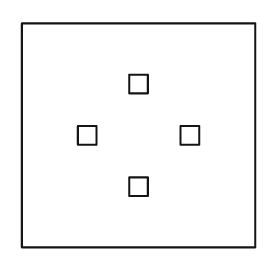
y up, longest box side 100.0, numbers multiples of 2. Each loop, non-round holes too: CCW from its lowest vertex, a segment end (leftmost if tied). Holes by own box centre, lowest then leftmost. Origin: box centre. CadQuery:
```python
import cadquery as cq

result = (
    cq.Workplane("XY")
    .moveTo(-50.0, -48.0)
    .lineTo(50.0, -48.0)
    .lineTo(50.0, 48.0)
    .lineTo(-50.0, 48.0)
    .close()
    .moveTo(-4.0, -26.0)
    .lineTo(4.0, -26.0)
    .lineTo(4.0, -18.0)
    .lineTo(-4.0, -18.0)
    .close()
    .moveTo(-26.0, -4.0)
    .lineTo(-18.0, -4.0)
    .lineTo(-18.0, 4.0)
    .lineTo(-26.0, 4.0)
    .close()
    .moveTo(18.0, -4.0)
    .lineTo(26.0, -4.0)
    .lineTo(26.0, 4.0)
    .lineTo(18.0, 4.0)
    .close()
    .moveTo(-4.0, 18.0)
    .lineTo(4.0, 18.0)
    .lineTo(4.0, 26.0)
    .lineTo(-4.0, 26.0)
    .close()
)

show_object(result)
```